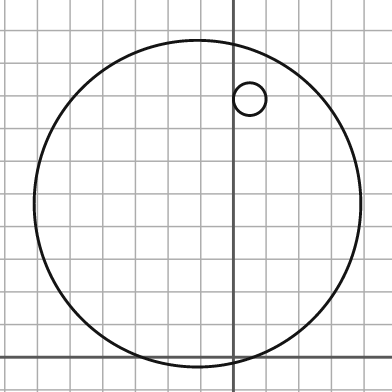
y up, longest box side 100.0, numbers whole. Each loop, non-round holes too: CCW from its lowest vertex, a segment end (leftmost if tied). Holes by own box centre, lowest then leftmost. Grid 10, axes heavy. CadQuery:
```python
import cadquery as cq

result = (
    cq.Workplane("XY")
    .moveTo(-11.0, 47.0)
    .circle(50.0)
    .moveTo(5.0, 79.0)
    .circle(5.0)
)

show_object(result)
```